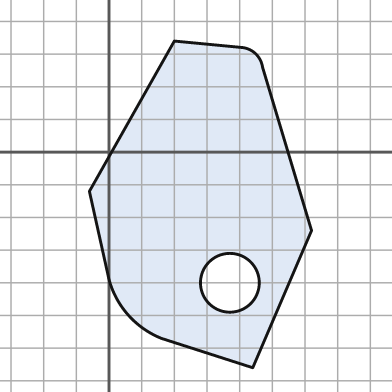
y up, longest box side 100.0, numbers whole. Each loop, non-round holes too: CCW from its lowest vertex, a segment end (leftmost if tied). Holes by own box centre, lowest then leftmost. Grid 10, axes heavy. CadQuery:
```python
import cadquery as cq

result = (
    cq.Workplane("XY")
    .moveTo(44.0, -66.0)
    .lineTo(62.0, -24.0)
    .lineTo(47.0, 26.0)
    .threePointArc((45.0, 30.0), (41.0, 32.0))
    .lineTo(20.0, 34.0)
    .lineTo(-6.0, -12.0)
    .lineTo(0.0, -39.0)
    .threePointArc((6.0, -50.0), (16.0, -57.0))
    .close()
    .moveTo(37.0, -40.0)
    .circle(9.0)
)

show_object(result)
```